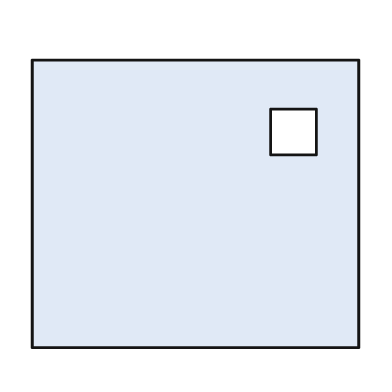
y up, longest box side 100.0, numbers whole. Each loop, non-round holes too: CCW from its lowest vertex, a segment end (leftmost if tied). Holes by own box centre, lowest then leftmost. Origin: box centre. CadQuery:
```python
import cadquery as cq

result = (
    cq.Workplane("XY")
    .moveTo(-50.0, -44.0)
    .lineTo(50.0, -44.0)
    .lineTo(50.0, 44.0)
    .lineTo(-50.0, 44.0)
    .close()
    .moveTo(23.0, 15.0)
    .lineTo(37.0, 15.0)
    .lineTo(37.0, 29.0)
    .lineTo(23.0, 29.0)
    .close()
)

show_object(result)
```